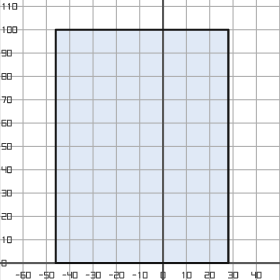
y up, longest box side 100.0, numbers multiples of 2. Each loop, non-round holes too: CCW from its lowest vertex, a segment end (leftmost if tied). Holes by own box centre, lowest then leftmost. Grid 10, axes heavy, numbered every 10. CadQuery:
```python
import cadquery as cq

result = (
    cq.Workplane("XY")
    .moveTo(-46.0, 0.0)
    .lineTo(28.0, 0.0)
    .lineTo(28.0, 100.0)
    .lineTo(-46.0, 100.0)
    .close()
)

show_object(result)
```